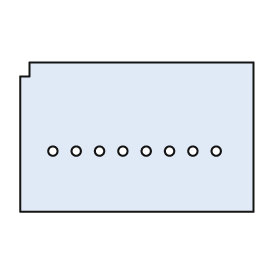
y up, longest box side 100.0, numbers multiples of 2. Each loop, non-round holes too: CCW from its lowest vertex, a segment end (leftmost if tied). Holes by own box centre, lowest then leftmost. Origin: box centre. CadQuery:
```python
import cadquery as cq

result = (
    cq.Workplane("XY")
    .moveTo(-50.0, -32.0)
    .lineTo(50.0, -32.0)
    .lineTo(50.0, 32.0)
    .lineTo(-46.0, 32.0)
    .lineTo(-46.0, 26.0)
    .lineTo(-50.0, 26.0)
    .close()
    .moveTo(-36.0, -6.0)
    .circle(2.0)
    .moveTo(-26.0, -6.0)
    .circle(2.0)
    .moveTo(-16.0, -6.0)
    .circle(2.0)
    .moveTo(-6.0, -6.0)
    .circle(2.0)
    .moveTo(4.0, -6.0)
    .circle(2.0)
    .moveTo(14.0, -6.0)
    .circle(2.0)
    .moveTo(24.0, -6.0)
    .circle(2.0)
    .moveTo(34.0, -6.0)
    .circle(2.0)
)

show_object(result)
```